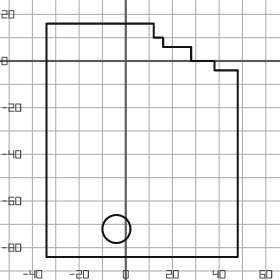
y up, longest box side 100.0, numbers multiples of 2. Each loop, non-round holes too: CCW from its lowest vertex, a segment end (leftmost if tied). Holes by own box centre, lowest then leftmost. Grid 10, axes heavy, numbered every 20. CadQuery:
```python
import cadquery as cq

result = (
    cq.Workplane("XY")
    .moveTo(-34.0, -84.0)
    .lineTo(48.0, -84.0)
    .lineTo(48.0, -4.0)
    .lineTo(38.0, -4.0)
    .lineTo(38.0, 0.0)
    .lineTo(28.0, 0.0)
    .lineTo(28.0, 6.0)
    .lineTo(16.0, 6.0)
    .lineTo(16.0, 10.0)
    .lineTo(12.0, 10.0)
    .lineTo(12.0, 16.0)
    .lineTo(-34.0, 16.0)
    .close()
    .moveTo(-4.0, -72.0)
    .circle(6.0)
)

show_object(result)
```